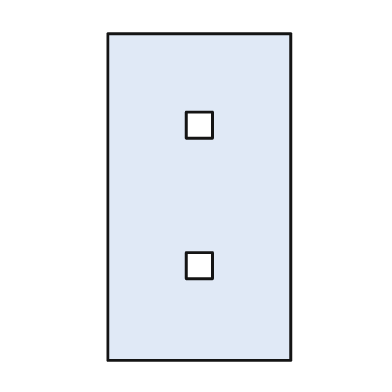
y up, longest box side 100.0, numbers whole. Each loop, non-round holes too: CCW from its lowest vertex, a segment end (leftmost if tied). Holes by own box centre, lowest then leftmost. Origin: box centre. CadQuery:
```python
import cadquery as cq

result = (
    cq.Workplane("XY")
    .moveTo(-28.0, -50.0)
    .lineTo(28.0, -50.0)
    .lineTo(28.0, 50.0)
    .lineTo(-28.0, 50.0)
    .close()
    .moveTo(-4.0, -25.0)
    .lineTo(4.0, -25.0)
    .lineTo(4.0, -17.0)
    .lineTo(-4.0, -17.0)
    .close()
    .moveTo(-4.0, 18.0)
    .lineTo(4.0, 18.0)
    .lineTo(4.0, 26.0)
    .lineTo(-4.0, 26.0)
    .close()
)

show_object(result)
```